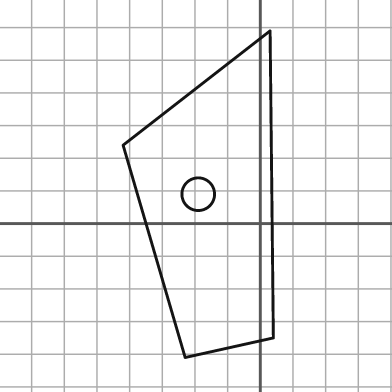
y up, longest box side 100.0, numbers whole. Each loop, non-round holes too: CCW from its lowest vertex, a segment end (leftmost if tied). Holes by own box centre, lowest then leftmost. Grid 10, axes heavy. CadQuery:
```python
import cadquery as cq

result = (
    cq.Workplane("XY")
    .moveTo(-23.0, -41.0)
    .lineTo(4.0, -35.0)
    .lineTo(3.0, 59.0)
    .lineTo(-42.0, 24.0)
    .close()
    .moveTo(-19.0, 9.0)
    .circle(5.0)
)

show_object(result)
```